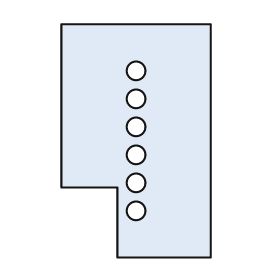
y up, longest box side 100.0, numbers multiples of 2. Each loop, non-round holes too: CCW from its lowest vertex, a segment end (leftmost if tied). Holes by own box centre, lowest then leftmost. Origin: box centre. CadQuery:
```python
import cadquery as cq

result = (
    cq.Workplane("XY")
    .moveTo(-8.0, -50.0)
    .lineTo(32.0, -50.0)
    .lineTo(32.0, 50.0)
    .lineTo(-32.0, 50.0)
    .lineTo(-32.0, -20.0)
    .lineTo(-8.0, -20.0)
    .close()
    .moveTo(0.0, -30.0)
    .circle(4.0)
    .moveTo(0.0, -18.0)
    .circle(4.0)
    .moveTo(0.0, -6.0)
    .circle(4.0)
    .moveTo(0.0, 6.0)
    .circle(4.0)
    .moveTo(0.0, 18.0)
    .circle(4.0)
    .moveTo(0.0, 30.0)
    .circle(4.0)
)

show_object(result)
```